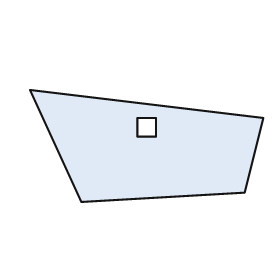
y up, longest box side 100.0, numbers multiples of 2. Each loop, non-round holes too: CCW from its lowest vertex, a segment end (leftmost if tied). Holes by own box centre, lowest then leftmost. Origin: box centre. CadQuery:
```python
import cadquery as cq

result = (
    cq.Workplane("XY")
    .moveTo(-28.0, -24.0)
    .lineTo(42.0, -20.0)
    .lineTo(50.0, 12.0)
    .lineTo(-50.0, 24.0)
    .close()
    .moveTo(-4.0, 4.0)
    .lineTo(4.0, 4.0)
    .lineTo(4.0, 12.0)
    .lineTo(-4.0, 12.0)
    .close()
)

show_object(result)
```